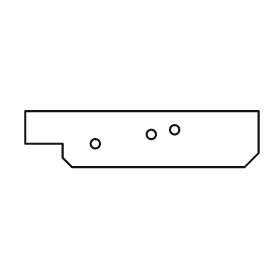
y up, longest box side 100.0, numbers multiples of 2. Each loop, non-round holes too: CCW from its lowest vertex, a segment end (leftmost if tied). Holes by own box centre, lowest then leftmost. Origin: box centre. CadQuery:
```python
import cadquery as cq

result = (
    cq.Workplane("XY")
    .moveTo(-30.0, -12.0)
    .lineTo(44.0, -12.0)
    .lineTo(50.0, -6.0)
    .lineTo(50.0, 12.0)
    .lineTo(-50.0, 12.0)
    .lineTo(-50.0, -2.0)
    .lineTo(-34.0, -2.0)
    .lineTo(-34.0, -8.0)
    .close()
    .moveTo(-20.0, -2.0)
    .circle(2.0)
    .moveTo(4.0, 2.0)
    .circle(2.0)
    .moveTo(14.0, 4.0)
    .circle(2.0)
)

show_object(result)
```